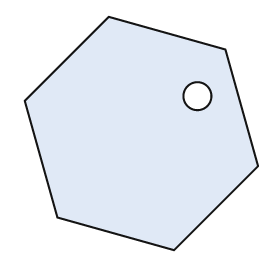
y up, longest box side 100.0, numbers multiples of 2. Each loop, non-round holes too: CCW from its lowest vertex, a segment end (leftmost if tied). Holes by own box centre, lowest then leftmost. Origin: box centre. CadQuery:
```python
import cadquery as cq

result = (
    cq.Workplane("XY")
    .moveTo(14.0, -50.0)
    .lineTo(50.0, -14.0)
    .lineTo(36.0, 36.0)
    .lineTo(-14.0, 50.0)
    .lineTo(-50.0, 14.0)
    .lineTo(-36.0, -36.0)
    .close()
    .moveTo(24.0, 16.0)
    .circle(6.0)
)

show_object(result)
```